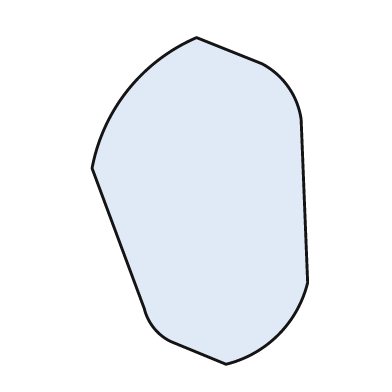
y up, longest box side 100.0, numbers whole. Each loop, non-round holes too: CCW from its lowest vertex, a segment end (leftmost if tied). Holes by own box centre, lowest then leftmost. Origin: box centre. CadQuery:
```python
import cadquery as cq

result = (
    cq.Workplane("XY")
    .moveTo(8.0, -50.0)
    .threePointArc((24.0, -41.0), (33.0, -25.0))
    .lineTo(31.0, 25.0)
    .threePointArc((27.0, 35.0), (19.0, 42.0))
    .lineTo(-1.0, 50.0)
    .threePointArc((-22.0, 34.0), (-33.0, 10.0))
    .lineTo(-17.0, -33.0)
    .threePointArc((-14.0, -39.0), (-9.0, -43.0))
    .close()
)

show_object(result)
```